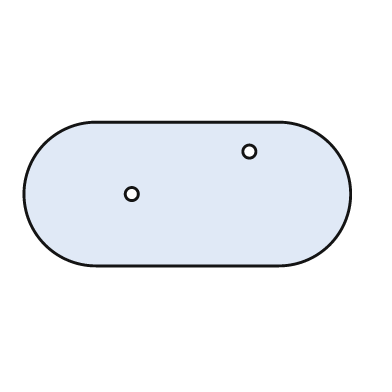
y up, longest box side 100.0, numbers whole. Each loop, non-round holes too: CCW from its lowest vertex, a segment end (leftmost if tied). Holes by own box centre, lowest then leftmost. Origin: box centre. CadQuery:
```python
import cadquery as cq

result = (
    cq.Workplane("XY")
    .moveTo(-28.0, -22.0)
    .lineTo(28.0, -22.0)
    .threePointArc((50.0, 0.0), (28.0, 22.0))
    .lineTo(-28.0, 22.0)
    .threePointArc((-50.0, 0.0), (-28.0, -22.0))
    .close()
    .moveTo(-17.0, 0.0)
    .circle(2.0)
    .moveTo(19.0, 13.0)
    .circle(2.0)
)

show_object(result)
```